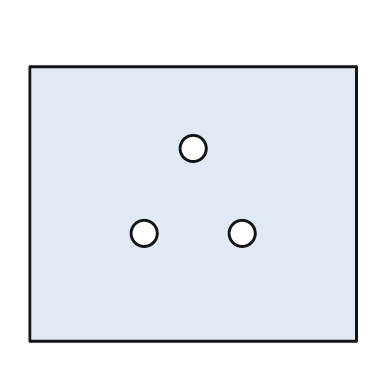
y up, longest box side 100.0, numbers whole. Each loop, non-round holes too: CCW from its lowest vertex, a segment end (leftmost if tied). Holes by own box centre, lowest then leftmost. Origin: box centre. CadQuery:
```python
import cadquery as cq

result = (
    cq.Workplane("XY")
    .moveTo(-50.0, -42.0)
    .lineTo(50.0, -42.0)
    .lineTo(50.0, 42.0)
    .lineTo(-50.0, 42.0)
    .close()
    .moveTo(-15.0, -9.0)
    .circle(4.0)
    .moveTo(15.0, -9.0)
    .circle(4.0)
    .moveTo(0.0, 17.0)
    .circle(4.0)
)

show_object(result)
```